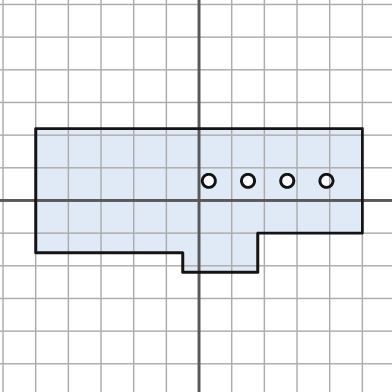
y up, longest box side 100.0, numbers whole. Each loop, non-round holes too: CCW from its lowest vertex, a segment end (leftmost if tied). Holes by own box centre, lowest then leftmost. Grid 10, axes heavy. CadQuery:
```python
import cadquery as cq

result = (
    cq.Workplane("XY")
    .moveTo(-5.0, -22.0)
    .lineTo(18.0, -22.0)
    .lineTo(18.0, -10.0)
    .lineTo(50.0, -10.0)
    .lineTo(50.0, 22.0)
    .lineTo(-50.0, 22.0)
    .lineTo(-50.0, -16.0)
    .lineTo(-5.0, -16.0)
    .close()
    .moveTo(3.0, 6.0)
    .circle(2.0)
    .moveTo(15.0, 6.0)
    .circle(2.0)
    .moveTo(27.0, 6.0)
    .circle(2.0)
    .moveTo(39.0, 6.0)
    .circle(2.0)
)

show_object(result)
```